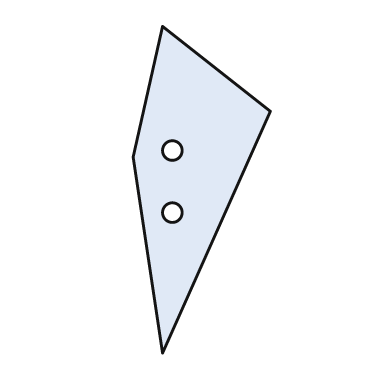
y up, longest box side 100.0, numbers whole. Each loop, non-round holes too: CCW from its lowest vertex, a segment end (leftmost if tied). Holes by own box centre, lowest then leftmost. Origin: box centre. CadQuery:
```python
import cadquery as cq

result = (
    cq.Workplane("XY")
    .moveTo(-12.0, -50.0)
    .lineTo(21.0, 24.0)
    .lineTo(-12.0, 50.0)
    .lineTo(-21.0, 10.0)
    .close()
    .moveTo(-9.0, -7.0)
    .circle(3.0)
    .moveTo(-9.0, 12.0)
    .circle(3.0)
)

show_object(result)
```